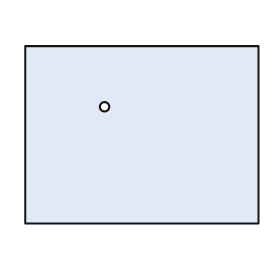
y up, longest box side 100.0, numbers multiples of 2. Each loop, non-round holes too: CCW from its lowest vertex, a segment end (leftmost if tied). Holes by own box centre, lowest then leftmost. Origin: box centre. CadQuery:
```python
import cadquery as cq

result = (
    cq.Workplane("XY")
    .moveTo(-50.0, -38.0)
    .lineTo(50.0, -38.0)
    .lineTo(50.0, 38.0)
    .lineTo(-50.0, 38.0)
    .close()
    .moveTo(-16.0, 12.0)
    .circle(2.0)
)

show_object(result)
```